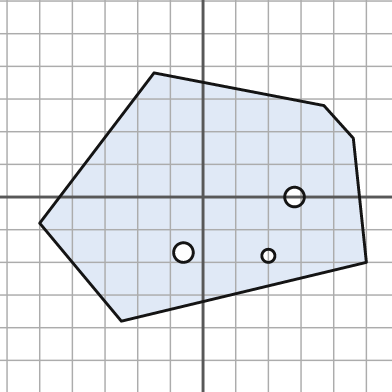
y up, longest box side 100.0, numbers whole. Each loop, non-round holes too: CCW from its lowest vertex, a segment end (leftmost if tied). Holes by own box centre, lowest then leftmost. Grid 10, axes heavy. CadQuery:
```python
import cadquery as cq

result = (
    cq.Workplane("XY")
    .moveTo(-25.0, -38.0)
    .lineTo(50.0, -20.0)
    .lineTo(46.0, 18.0)
    .lineTo(37.0, 28.0)
    .lineTo(-15.0, 38.0)
    .lineTo(-50.0, -8.0)
    .close()
    .moveTo(20.0, -18.0)
    .circle(2.0)
    .moveTo(-6.0, -17.0)
    .circle(3.0)
    .moveTo(28.0, 0.0)
    .circle(3.0)
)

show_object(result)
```